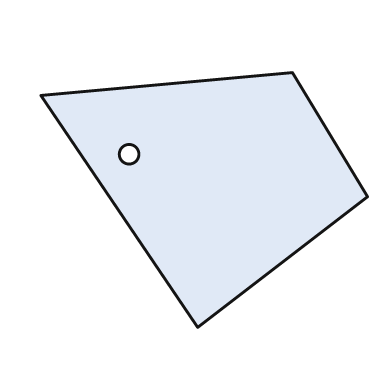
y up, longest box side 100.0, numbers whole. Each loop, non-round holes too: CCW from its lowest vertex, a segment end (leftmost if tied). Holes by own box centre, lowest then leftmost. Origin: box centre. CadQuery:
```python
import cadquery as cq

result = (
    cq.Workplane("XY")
    .moveTo(-2.0, -39.0)
    .lineTo(50.0, 1.0)
    .lineTo(27.0, 39.0)
    .lineTo(-50.0, 32.0)
    .close()
    .moveTo(-23.0, 14.0)
    .circle(3.0)
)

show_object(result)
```